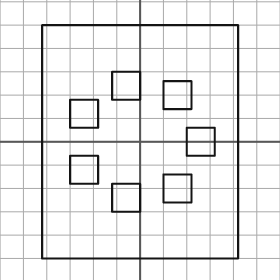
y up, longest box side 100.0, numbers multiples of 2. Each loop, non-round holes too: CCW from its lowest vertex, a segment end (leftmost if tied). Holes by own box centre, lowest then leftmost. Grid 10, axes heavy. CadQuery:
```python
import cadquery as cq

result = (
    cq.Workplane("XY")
    .moveTo(-42.0, -50.0)
    .lineTo(42.0, -50.0)
    .lineTo(42.0, 50.0)
    .lineTo(-42.0, 50.0)
    .close()
    .moveTo(-12.0, -30.0)
    .lineTo(0.0, -30.0)
    .lineTo(0.0, -18.0)
    .lineTo(-12.0, -18.0)
    .close()
    .moveTo(10.0, -26.0)
    .lineTo(22.0, -26.0)
    .lineTo(22.0, -14.0)
    .lineTo(10.0, -14.0)
    .close()
    .moveTo(-30.0, -18.0)
    .lineTo(-18.0, -18.0)
    .lineTo(-18.0, -6.0)
    .lineTo(-30.0, -6.0)
    .close()
    .moveTo(20.0, -6.0)
    .lineTo(32.0, -6.0)
    .lineTo(32.0, 6.0)
    .lineTo(20.0, 6.0)
    .close()
    .moveTo(-30.0, 6.0)
    .lineTo(-18.0, 6.0)
    .lineTo(-18.0, 18.0)
    .lineTo(-30.0, 18.0)
    .close()
    .moveTo(10.0, 14.0)
    .lineTo(22.0, 14.0)
    .lineTo(22.0, 26.0)
    .lineTo(10.0, 26.0)
    .close()
    .moveTo(-12.0, 18.0)
    .lineTo(0.0, 18.0)
    .lineTo(0.0, 30.0)
    .lineTo(-12.0, 30.0)
    .close()
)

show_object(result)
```